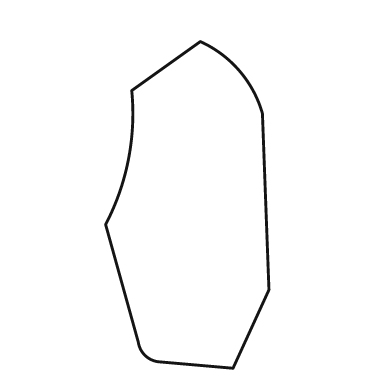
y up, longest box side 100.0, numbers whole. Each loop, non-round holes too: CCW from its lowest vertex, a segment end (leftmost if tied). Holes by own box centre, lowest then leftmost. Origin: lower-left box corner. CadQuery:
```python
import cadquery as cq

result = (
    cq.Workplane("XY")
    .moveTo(39.0, 0.0)
    .lineTo(50.0, 24.0)
    .lineTo(48.0, 78.0)
    .threePointArc((41.0, 91.0), (29.0, 100.0))
    .lineTo(8.0, 85.0)
    .threePointArc((7.0, 64.0), (0.0, 44.0))
    .lineTo(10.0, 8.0)
    .threePointArc((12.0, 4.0), (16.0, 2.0))
    .close()
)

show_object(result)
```